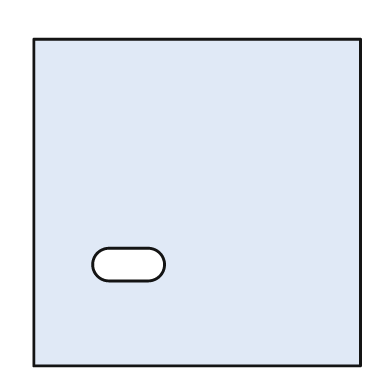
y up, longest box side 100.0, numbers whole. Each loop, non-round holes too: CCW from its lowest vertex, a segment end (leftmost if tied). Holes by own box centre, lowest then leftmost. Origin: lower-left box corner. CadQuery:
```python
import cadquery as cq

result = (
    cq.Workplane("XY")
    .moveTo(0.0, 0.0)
    .lineTo(100.0, 0.0)
    .lineTo(100.0, 100.0)
    .lineTo(0.0, 100.0)
    .close()
    .moveTo(23.0, 26.0)
    .lineTo(35.0, 26.0)
    .threePointArc((40.0, 31.0), (35.0, 36.0))
    .lineTo(23.0, 36.0)
    .threePointArc((18.0, 31.0), (23.0, 26.0))
    .close()
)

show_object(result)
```